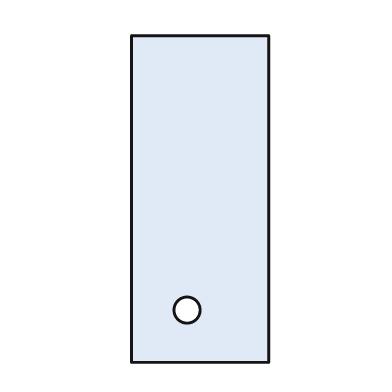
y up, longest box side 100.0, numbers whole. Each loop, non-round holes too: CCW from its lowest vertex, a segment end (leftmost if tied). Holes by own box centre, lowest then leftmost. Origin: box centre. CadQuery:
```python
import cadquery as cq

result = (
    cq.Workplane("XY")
    .moveTo(-21.0, -50.0)
    .lineTo(21.0, -50.0)
    .lineTo(21.0, 50.0)
    .lineTo(-21.0, 50.0)
    .close()
    .moveTo(-4.0, -34.0)
    .circle(4.0)
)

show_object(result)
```